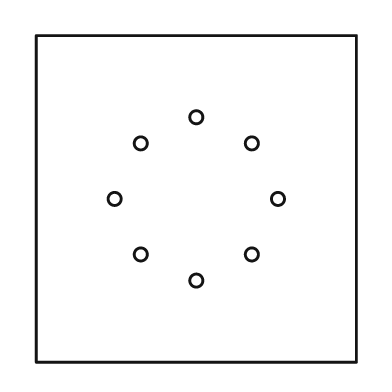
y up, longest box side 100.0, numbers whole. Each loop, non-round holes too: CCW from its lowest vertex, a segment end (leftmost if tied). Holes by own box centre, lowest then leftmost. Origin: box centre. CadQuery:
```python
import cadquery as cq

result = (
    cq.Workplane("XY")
    .moveTo(-49.0, -50.0)
    .lineTo(49.0, -50.0)
    .lineTo(49.0, 50.0)
    .lineTo(-49.0, 50.0)
    .close()
    .moveTo(0.0, -25.0)
    .circle(2.0)
    .moveTo(-17.0, -17.0)
    .circle(2.0)
    .moveTo(17.0, -17.0)
    .circle(2.0)
    .moveTo(-25.0, 0.0)
    .circle(2.0)
    .moveTo(25.0, 0.0)
    .circle(2.0)
    .moveTo(-17.0, 17.0)
    .circle(2.0)
    .moveTo(17.0, 17.0)
    .circle(2.0)
    .moveTo(0.0, 25.0)
    .circle(2.0)
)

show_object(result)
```